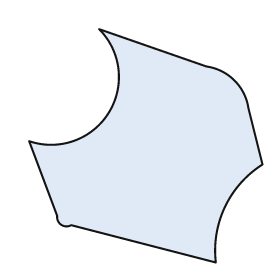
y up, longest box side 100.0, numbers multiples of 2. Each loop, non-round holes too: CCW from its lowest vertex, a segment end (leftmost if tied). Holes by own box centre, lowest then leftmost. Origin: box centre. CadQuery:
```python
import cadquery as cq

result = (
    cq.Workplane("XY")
    .moveTo(30.0, -50.0)
    .threePointArc((34.0, -26.0), (50.0, -8.0))
    .lineTo(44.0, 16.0)
    .threePointArc((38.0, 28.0), (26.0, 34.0))
    .lineTo(-20.0, 50.0)
    .threePointArc((-16.0, 14.0), (-50.0, 2.0))
    .lineTo(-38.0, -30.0)
    .threePointArc((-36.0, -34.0), (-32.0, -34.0))
    .close()
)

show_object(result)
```